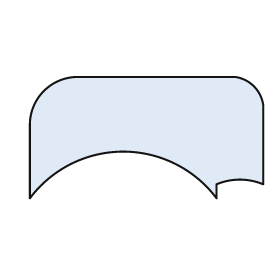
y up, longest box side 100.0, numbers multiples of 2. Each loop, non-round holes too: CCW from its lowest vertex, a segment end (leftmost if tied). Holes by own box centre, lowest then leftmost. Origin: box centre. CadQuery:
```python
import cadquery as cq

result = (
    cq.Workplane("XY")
    .moveTo(-50.0, -26.0)
    .threePointArc((-10.0, -6.0), (30.0, -26.0))
    .lineTo(30.0, -20.0)
    .threePointArc((40.0, -18.0), (50.0, -20.0))
    .lineTo(50.0, 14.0)
    .threePointArc((46.0, 22.0), (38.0, 26.0))
    .lineTo(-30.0, 26.0)
    .threePointArc((-44.0, 20.0), (-50.0, 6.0))
    .close()
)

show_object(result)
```